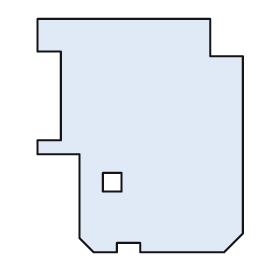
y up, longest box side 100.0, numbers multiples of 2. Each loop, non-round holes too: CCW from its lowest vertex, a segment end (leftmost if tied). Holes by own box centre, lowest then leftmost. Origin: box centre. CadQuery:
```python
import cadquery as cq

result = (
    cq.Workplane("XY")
    .moveTo(-20.0, -50.0)
    .lineTo(-10.0, -50.0)
    .lineTo(-10.0, -46.0)
    .lineTo(0.0, -46.0)
    .lineTo(0.0, -50.0)
    .lineTo(36.0, -50.0)
    .lineTo(44.0, -42.0)
    .lineTo(44.0, 34.0)
    .lineTo(30.0, 34.0)
    .lineTo(30.0, 50.0)
    .lineTo(-44.0, 50.0)
    .lineTo(-44.0, 36.0)
    .lineTo(-34.0, 36.0)
    .lineTo(-34.0, -2.0)
    .lineTo(-44.0, -2.0)
    .lineTo(-44.0, -8.0)
    .lineTo(-26.0, -8.0)
    .lineTo(-26.0, -44.0)
    .close()
    .moveTo(-16.0, -24.0)
    .lineTo(-8.0, -24.0)
    .lineTo(-8.0, -16.0)
    .lineTo(-16.0, -16.0)
    .close()
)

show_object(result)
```